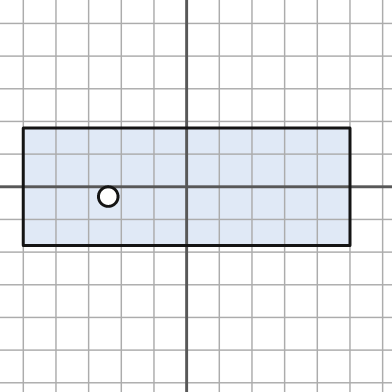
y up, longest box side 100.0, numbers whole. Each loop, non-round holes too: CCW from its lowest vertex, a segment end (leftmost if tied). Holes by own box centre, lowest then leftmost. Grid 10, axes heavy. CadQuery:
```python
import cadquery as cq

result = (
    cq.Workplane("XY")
    .moveTo(-50.0, -18.0)
    .lineTo(50.0, -18.0)
    .lineTo(50.0, 18.0)
    .lineTo(-50.0, 18.0)
    .close()
    .moveTo(-24.0, -3.0)
    .circle(3.0)
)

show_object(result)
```